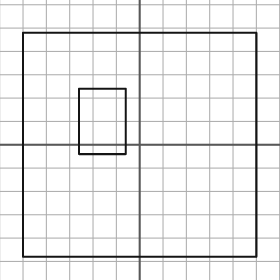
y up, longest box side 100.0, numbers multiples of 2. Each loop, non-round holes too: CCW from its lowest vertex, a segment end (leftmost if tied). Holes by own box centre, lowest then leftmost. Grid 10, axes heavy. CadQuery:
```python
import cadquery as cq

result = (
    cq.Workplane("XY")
    .moveTo(-50.0, -48.0)
    .lineTo(50.0, -48.0)
    .lineTo(50.0, 48.0)
    .lineTo(-50.0, 48.0)
    .close()
    .moveTo(-26.0, -4.0)
    .lineTo(-6.0, -4.0)
    .lineTo(-6.0, 24.0)
    .lineTo(-26.0, 24.0)
    .close()
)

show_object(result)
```